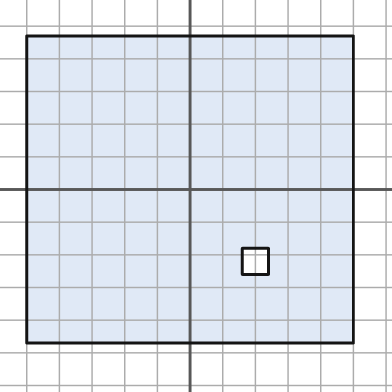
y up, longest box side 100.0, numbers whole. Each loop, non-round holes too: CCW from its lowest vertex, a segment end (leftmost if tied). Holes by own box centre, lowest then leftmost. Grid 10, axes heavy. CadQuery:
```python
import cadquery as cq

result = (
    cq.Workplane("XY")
    .moveTo(-50.0, -47.0)
    .lineTo(50.0, -47.0)
    .lineTo(50.0, 47.0)
    .lineTo(-50.0, 47.0)
    .close()
    .moveTo(16.0, -26.0)
    .lineTo(24.0, -26.0)
    .lineTo(24.0, -18.0)
    .lineTo(16.0, -18.0)
    .close()
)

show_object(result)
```